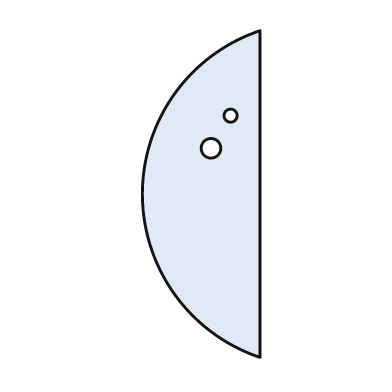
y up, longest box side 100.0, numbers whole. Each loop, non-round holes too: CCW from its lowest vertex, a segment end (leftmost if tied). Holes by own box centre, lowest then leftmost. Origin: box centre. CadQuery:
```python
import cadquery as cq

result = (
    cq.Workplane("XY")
    .moveTo(18.0, -50.0)
    .lineTo(18.0, 50.0)
    .threePointArc((-18.0, 0.0), (18.0, -50.0))
    .close()
    .moveTo(3.0, 14.0)
    .circle(3.0)
    .moveTo(9.0, 24.0)
    .circle(2.0)
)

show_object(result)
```